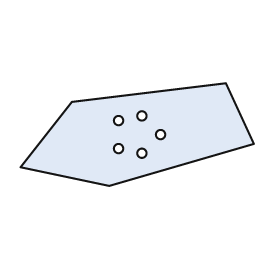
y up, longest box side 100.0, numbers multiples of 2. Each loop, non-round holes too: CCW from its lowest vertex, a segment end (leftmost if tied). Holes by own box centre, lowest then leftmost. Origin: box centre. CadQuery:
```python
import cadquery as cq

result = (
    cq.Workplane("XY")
    .moveTo(-12.0, -22.0)
    .lineTo(50.0, -4.0)
    .lineTo(38.0, 22.0)
    .lineTo(-28.0, 14.0)
    .lineTo(-50.0, -14.0)
    .close()
    .moveTo(2.0, -8.0)
    .circle(2.0)
    .moveTo(-8.0, -6.0)
    .circle(2.0)
    .moveTo(10.0, 0.0)
    .circle(2.0)
    .moveTo(-8.0, 6.0)
    .circle(2.0)
    .moveTo(2.0, 8.0)
    .circle(2.0)
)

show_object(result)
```